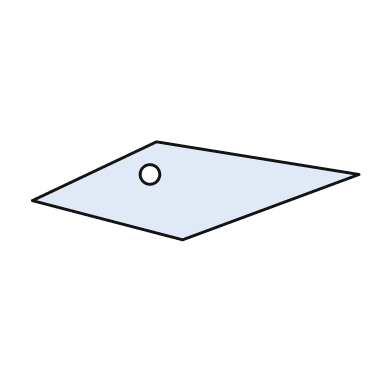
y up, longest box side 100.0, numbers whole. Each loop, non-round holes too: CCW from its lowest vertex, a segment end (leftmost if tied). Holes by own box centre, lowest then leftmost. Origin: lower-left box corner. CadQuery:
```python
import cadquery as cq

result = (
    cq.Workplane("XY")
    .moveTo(46.0, 0.0)
    .lineTo(100.0, 20.0)
    .lineTo(38.0, 30.0)
    .lineTo(0.0, 12.0)
    .close()
    .moveTo(36.0, 20.0)
    .circle(3.0)
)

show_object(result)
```